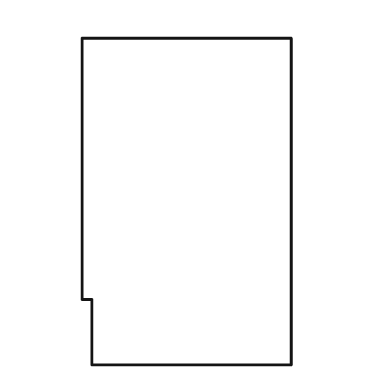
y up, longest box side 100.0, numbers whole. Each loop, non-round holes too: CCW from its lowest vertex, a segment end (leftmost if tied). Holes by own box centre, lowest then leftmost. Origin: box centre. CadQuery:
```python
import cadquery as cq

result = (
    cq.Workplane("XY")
    .moveTo(-29.0, -50.0)
    .lineTo(32.0, -50.0)
    .lineTo(32.0, 50.0)
    .lineTo(-32.0, 50.0)
    .lineTo(-32.0, -30.0)
    .lineTo(-29.0, -30.0)
    .close()
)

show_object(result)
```